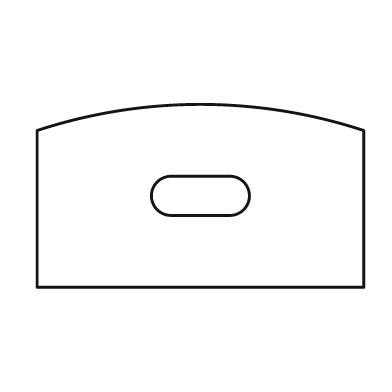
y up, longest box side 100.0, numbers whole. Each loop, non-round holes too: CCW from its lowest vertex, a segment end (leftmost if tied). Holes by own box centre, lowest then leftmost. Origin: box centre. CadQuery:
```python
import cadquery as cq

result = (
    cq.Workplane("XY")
    .moveTo(-50.0, -28.0)
    .lineTo(50.0, -28.0)
    .lineTo(50.0, 20.0)
    .threePointArc((0.0, 28.0), (-50.0, 20.0))
    .close()
    .moveTo(-9.0, -6.0)
    .lineTo(9.0, -6.0)
    .threePointArc((15.0, 0.0), (9.0, 6.0))
    .lineTo(-9.0, 6.0)
    .threePointArc((-15.0, 0.0), (-9.0, -6.0))
    .close()
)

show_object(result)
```